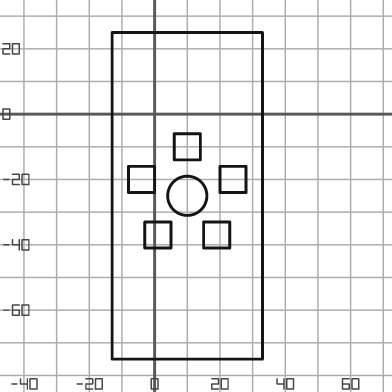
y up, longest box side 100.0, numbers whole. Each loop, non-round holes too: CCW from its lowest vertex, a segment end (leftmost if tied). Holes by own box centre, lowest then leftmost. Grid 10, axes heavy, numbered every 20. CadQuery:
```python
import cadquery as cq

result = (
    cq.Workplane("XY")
    .moveTo(-13.0, -75.0)
    .lineTo(33.0, -75.0)
    .lineTo(33.0, 25.0)
    .lineTo(-13.0, 25.0)
    .close()
    .moveTo(-3.0, -41.0)
    .lineTo(5.0, -41.0)
    .lineTo(5.0, -33.0)
    .lineTo(-3.0, -33.0)
    .close()
    .moveTo(15.0, -41.0)
    .lineTo(23.0, -41.0)
    .lineTo(23.0, -33.0)
    .lineTo(15.0, -33.0)
    .close()
    .moveTo(10.0, -25.0)
    .circle(6.0)
    .moveTo(-8.0, -24.0)
    .lineTo(0.0, -24.0)
    .lineTo(0.0, -16.0)
    .lineTo(-8.0, -16.0)
    .close()
    .moveTo(20.0, -24.0)
    .lineTo(28.0, -24.0)
    .lineTo(28.0, -16.0)
    .lineTo(20.0, -16.0)
    .close()
    .moveTo(6.0, -14.0)
    .lineTo(14.0, -14.0)
    .lineTo(14.0, -6.0)
    .lineTo(6.0, -6.0)
    .close()
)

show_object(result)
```